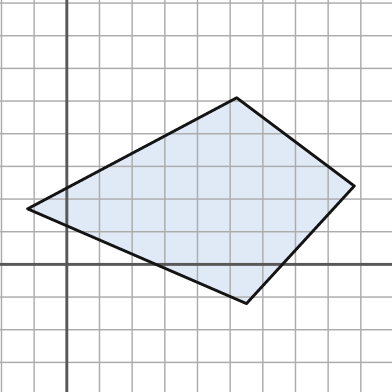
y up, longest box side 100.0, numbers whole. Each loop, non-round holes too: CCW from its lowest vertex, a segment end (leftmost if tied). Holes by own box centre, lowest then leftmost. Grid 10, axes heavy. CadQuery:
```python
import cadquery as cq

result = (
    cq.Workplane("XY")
    .moveTo(55.0, -12.0)
    .lineTo(88.0, 24.0)
    .lineTo(52.0, 51.0)
    .lineTo(-12.0, 17.0)
    .close()
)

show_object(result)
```